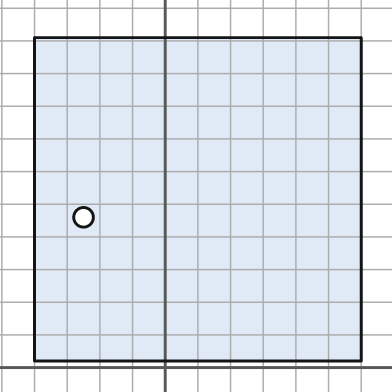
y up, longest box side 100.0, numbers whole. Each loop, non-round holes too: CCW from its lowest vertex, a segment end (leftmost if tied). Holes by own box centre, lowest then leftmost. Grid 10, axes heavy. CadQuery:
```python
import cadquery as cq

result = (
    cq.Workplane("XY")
    .moveTo(-40.0, 2.0)
    .lineTo(60.0, 2.0)
    .lineTo(60.0, 101.0)
    .lineTo(-40.0, 101.0)
    .close()
    .moveTo(-25.0, 46.0)
    .circle(3.0)
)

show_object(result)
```